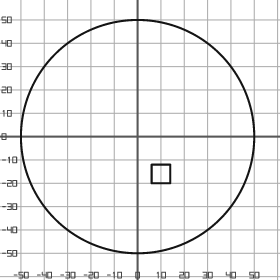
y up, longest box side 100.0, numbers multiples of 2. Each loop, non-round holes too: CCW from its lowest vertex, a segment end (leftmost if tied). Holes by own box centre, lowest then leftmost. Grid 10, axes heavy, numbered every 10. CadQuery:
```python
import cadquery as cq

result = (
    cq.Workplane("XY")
    .moveTo(0.0, 0.0)
    .circle(50.0)
    .moveTo(6.0, -20.0)
    .lineTo(14.0, -20.0)
    .lineTo(14.0, -12.0)
    .lineTo(6.0, -12.0)
    .close()
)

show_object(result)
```